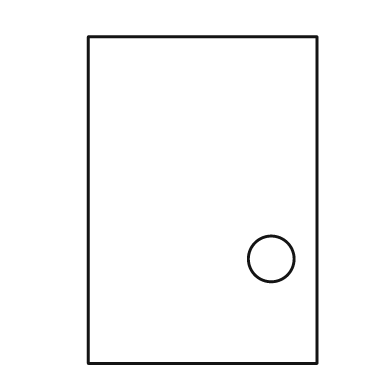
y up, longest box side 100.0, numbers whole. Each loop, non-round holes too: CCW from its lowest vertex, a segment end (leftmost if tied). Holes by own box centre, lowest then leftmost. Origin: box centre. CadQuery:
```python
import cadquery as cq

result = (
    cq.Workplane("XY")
    .moveTo(-35.0, -50.0)
    .lineTo(35.0, -50.0)
    .lineTo(35.0, 50.0)
    .lineTo(-35.0, 50.0)
    .close()
    .moveTo(21.0, -18.0)
    .circle(7.0)
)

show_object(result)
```